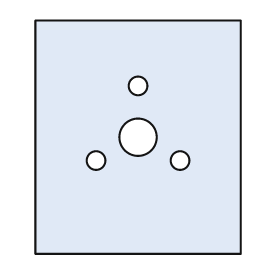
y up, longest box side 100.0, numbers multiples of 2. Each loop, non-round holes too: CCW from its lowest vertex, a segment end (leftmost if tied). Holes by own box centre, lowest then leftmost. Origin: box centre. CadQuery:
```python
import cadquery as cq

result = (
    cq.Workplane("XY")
    .moveTo(-44.0, -50.0)
    .lineTo(44.0, -50.0)
    .lineTo(44.0, 50.0)
    .lineTo(-44.0, 50.0)
    .close()
    .moveTo(-18.0, -10.0)
    .circle(4.0)
    .moveTo(18.0, -10.0)
    .circle(4.0)
    .moveTo(0.0, 0.0)
    .circle(8.0)
    .moveTo(0.0, 22.0)
    .circle(4.0)
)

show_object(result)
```